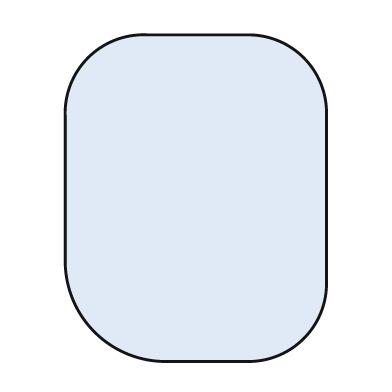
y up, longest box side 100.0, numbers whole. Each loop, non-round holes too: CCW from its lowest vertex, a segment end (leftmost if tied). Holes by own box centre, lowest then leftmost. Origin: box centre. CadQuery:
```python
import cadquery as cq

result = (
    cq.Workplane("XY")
    .moveTo(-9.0, -50.0)
    .lineTo(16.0, -50.0)
    .threePointArc((33.0, -43.0), (40.0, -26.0))
    .lineTo(40.0, 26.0)
    .threePointArc((33.0, 43.0), (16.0, 50.0))
    .lineTo(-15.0, 50.0)
    .threePointArc((-33.0, 43.0), (-40.0, 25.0))
    .lineTo(-40.0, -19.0)
    .threePointArc((-31.0, -41.0), (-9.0, -50.0))
    .close()
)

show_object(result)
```